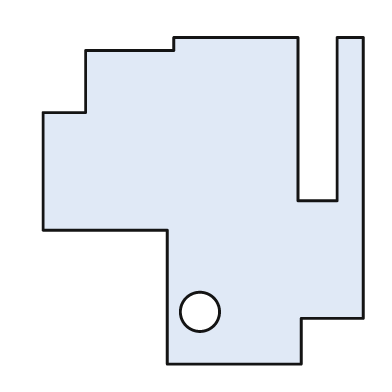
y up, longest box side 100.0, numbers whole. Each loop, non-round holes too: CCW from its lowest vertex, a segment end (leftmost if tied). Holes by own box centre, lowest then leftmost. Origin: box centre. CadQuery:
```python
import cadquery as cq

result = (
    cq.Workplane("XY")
    .moveTo(-11.0, -50.0)
    .lineTo(30.0, -50.0)
    .lineTo(30.0, -36.0)
    .lineTo(49.0, -36.0)
    .lineTo(49.0, 50.0)
    .lineTo(41.0, 50.0)
    .lineTo(41.0, 0.0)
    .lineTo(29.0, 0.0)
    .lineTo(29.0, 50.0)
    .lineTo(-9.0, 50.0)
    .lineTo(-9.0, 46.0)
    .lineTo(-36.0, 46.0)
    .lineTo(-36.0, 27.0)
    .lineTo(-49.0, 27.0)
    .lineTo(-49.0, -9.0)
    .lineTo(-11.0, -9.0)
    .close()
    .moveTo(-1.0, -34.0)
    .circle(6.0)
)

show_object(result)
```